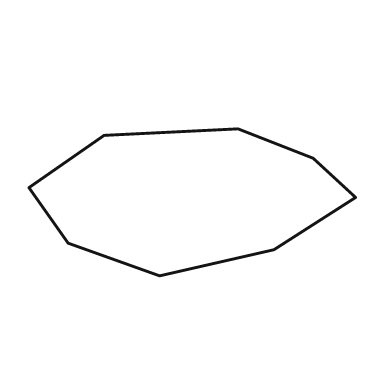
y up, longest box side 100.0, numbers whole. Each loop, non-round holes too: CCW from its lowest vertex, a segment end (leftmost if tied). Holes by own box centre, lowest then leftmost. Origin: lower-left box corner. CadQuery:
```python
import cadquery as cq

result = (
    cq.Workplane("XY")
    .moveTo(40.0, 0.0)
    .lineTo(75.0, 8.0)
    .lineTo(100.0, 24.0)
    .lineTo(87.0, 36.0)
    .lineTo(64.0, 45.0)
    .lineTo(23.0, 43.0)
    .lineTo(0.0, 27.0)
    .lineTo(12.0, 10.0)
    .close()
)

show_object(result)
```